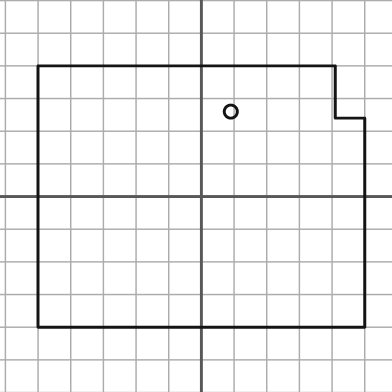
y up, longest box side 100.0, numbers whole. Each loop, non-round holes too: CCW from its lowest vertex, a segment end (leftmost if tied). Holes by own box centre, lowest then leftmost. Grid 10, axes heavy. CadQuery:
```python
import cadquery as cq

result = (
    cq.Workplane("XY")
    .moveTo(-50.0, -40.0)
    .lineTo(50.0, -40.0)
    .lineTo(50.0, 24.0)
    .lineTo(41.0, 24.0)
    .lineTo(41.0, 40.0)
    .lineTo(-50.0, 40.0)
    .close()
    .moveTo(9.0, 26.0)
    .circle(2.0)
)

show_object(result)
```